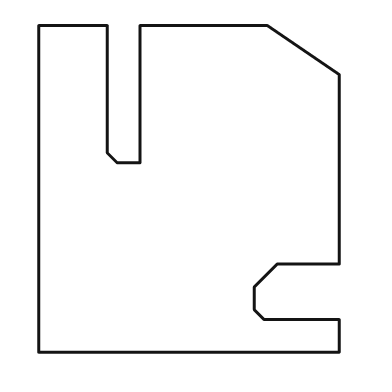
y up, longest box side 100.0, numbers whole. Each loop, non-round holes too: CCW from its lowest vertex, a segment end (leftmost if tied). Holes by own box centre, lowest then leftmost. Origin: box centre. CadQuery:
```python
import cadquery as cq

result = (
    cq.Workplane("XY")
    .moveTo(-46.0, -50.0)
    .lineTo(46.0, -50.0)
    .lineTo(46.0, -40.0)
    .lineTo(23.0, -40.0)
    .lineTo(20.0, -37.0)
    .lineTo(20.0, -30.0)
    .lineTo(27.0, -23.0)
    .lineTo(46.0, -23.0)
    .lineTo(46.0, 35.0)
    .lineTo(24.0, 50.0)
    .lineTo(-15.0, 50.0)
    .lineTo(-15.0, 8.0)
    .lineTo(-22.0, 8.0)
    .lineTo(-25.0, 11.0)
    .lineTo(-25.0, 50.0)
    .lineTo(-46.0, 50.0)
    .close()
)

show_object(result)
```